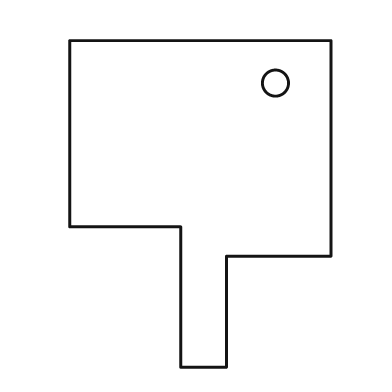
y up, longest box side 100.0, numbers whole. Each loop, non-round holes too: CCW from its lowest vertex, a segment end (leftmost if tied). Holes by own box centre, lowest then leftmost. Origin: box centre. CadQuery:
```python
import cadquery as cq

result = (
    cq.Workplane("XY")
    .moveTo(-6.0, -50.0)
    .lineTo(8.0, -50.0)
    .lineTo(8.0, -16.0)
    .lineTo(40.0, -16.0)
    .lineTo(40.0, 50.0)
    .lineTo(-40.0, 50.0)
    .lineTo(-40.0, -7.0)
    .lineTo(-6.0, -7.0)
    .close()
    .moveTo(23.0, 37.0)
    .circle(4.0)
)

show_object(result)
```